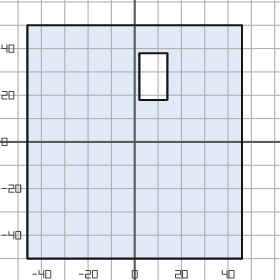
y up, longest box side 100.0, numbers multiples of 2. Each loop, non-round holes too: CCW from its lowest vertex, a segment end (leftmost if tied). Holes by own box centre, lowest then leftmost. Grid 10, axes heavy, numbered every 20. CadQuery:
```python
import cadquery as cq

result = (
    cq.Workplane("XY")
    .moveTo(-46.0, -50.0)
    .lineTo(46.0, -50.0)
    .lineTo(46.0, 50.0)
    .lineTo(-46.0, 50.0)
    .close()
    .moveTo(2.0, 18.0)
    .lineTo(14.0, 18.0)
    .lineTo(14.0, 38.0)
    .lineTo(2.0, 38.0)
    .close()
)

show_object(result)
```